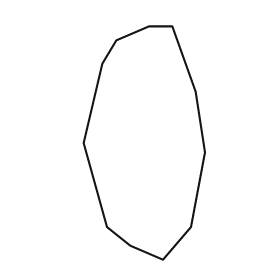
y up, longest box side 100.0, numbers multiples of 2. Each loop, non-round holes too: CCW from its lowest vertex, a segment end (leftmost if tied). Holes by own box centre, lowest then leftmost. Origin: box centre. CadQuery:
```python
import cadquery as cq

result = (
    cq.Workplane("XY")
    .moveTo(8.0, -50.0)
    .lineTo(20.0, -36.0)
    .lineTo(26.0, -4.0)
    .lineTo(22.0, 22.0)
    .lineTo(12.0, 50.0)
    .lineTo(2.0, 50.0)
    .lineTo(-12.0, 44.0)
    .lineTo(-18.0, 34.0)
    .lineTo(-26.0, 0.0)
    .lineTo(-16.0, -36.0)
    .lineTo(-6.0, -44.0)
    .close()
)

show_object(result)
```